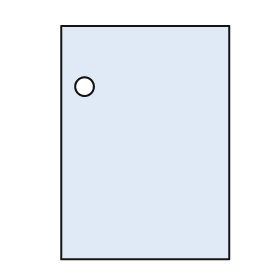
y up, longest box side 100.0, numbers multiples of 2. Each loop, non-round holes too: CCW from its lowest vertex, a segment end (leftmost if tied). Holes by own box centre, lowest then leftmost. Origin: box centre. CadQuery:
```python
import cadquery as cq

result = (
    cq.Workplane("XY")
    .moveTo(-36.0, -50.0)
    .lineTo(36.0, -50.0)
    .lineTo(36.0, 50.0)
    .lineTo(-36.0, 50.0)
    .close()
    .moveTo(-26.0, 24.0)
    .circle(4.0)
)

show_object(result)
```